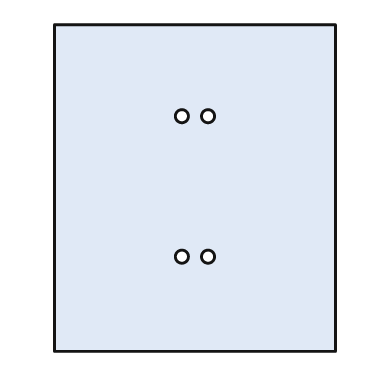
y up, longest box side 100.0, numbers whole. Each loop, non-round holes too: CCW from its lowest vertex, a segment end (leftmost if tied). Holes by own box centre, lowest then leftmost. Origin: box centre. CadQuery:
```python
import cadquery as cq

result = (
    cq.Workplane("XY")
    .moveTo(-43.0, -50.0)
    .lineTo(43.0, -50.0)
    .lineTo(43.0, 50.0)
    .lineTo(-43.0, 50.0)
    .close()
    .moveTo(-4.0, -21.0)
    .circle(2.0)
    .moveTo(4.0, -21.0)
    .circle(2.0)
    .moveTo(-4.0, 22.0)
    .circle(2.0)
    .moveTo(4.0, 22.0)
    .circle(2.0)
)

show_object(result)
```